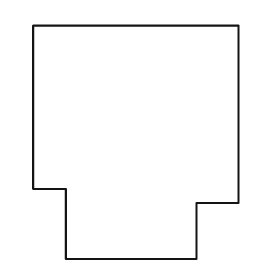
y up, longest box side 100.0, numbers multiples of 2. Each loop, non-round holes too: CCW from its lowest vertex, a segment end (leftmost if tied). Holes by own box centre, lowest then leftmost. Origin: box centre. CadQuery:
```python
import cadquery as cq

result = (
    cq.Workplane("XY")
    .moveTo(-30.0, -50.0)
    .lineTo(26.0, -50.0)
    .lineTo(26.0, -26.0)
    .lineTo(44.0, -26.0)
    .lineTo(44.0, 50.0)
    .lineTo(-44.0, 50.0)
    .lineTo(-44.0, -20.0)
    .lineTo(-30.0, -20.0)
    .close()
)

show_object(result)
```